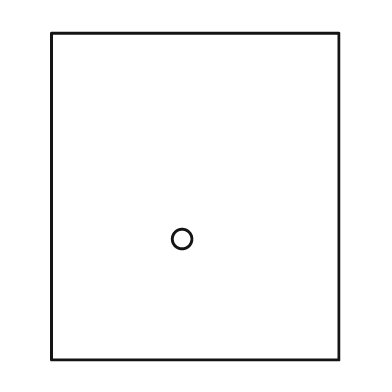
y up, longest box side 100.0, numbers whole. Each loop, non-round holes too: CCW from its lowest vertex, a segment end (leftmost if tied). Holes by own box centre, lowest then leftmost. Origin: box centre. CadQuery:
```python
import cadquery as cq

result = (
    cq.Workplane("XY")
    .moveTo(-44.0, -50.0)
    .lineTo(44.0, -50.0)
    .lineTo(44.0, 50.0)
    .lineTo(-44.0, 50.0)
    .close()
    .moveTo(-4.0, -13.0)
    .circle(3.0)
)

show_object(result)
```